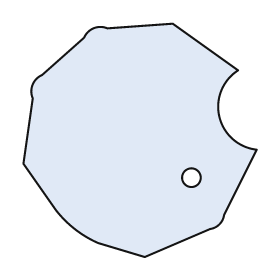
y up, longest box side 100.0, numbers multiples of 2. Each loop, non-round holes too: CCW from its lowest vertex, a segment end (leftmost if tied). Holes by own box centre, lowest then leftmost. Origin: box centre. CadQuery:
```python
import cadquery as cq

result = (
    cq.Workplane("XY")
    .moveTo(2.0, -50.0)
    .lineTo(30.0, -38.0)
    .threePointArc((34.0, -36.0), (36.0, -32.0))
    .lineTo(50.0, -4.0)
    .threePointArc((34.0, 10.0), (42.0, 30.0))
    .lineTo(14.0, 50.0)
    .lineTo(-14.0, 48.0)
    .threePointArc((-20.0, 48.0), (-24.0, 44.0))
    .lineTo(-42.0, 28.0)
    .threePointArc((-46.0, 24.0), (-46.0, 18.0))
    .lineTo(-50.0, -10.0)
    .lineTo(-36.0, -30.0)
    .threePointArc((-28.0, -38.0), (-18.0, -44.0))
    .close()
    .moveTo(22.0, -16.0)
    .circle(4.0)
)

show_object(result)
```